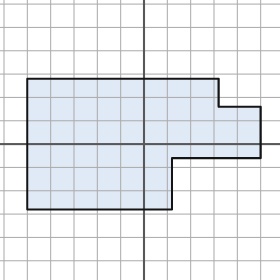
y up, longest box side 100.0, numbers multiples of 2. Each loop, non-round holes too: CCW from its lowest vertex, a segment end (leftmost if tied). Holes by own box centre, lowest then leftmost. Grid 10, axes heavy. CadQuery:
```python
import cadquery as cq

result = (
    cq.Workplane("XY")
    .moveTo(-50.0, -28.0)
    .lineTo(12.0, -28.0)
    .lineTo(12.0, -6.0)
    .lineTo(50.0, -6.0)
    .lineTo(50.0, 16.0)
    .lineTo(32.0, 16.0)
    .lineTo(32.0, 28.0)
    .lineTo(-50.0, 28.0)
    .close()
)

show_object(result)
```